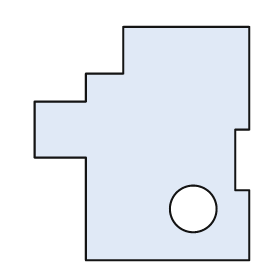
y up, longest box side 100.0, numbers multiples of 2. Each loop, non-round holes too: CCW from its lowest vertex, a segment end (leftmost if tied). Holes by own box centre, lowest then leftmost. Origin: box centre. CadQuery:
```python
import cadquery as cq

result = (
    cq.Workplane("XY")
    .moveTo(-24.0, -50.0)
    .lineTo(46.0, -50.0)
    .lineTo(46.0, -20.0)
    .lineTo(40.0, -20.0)
    .lineTo(40.0, 6.0)
    .lineTo(46.0, 6.0)
    .lineTo(46.0, 50.0)
    .lineTo(-8.0, 50.0)
    .lineTo(-8.0, 30.0)
    .lineTo(-24.0, 30.0)
    .lineTo(-24.0, 18.0)
    .lineTo(-46.0, 18.0)
    .lineTo(-46.0, -6.0)
    .lineTo(-24.0, -6.0)
    .close()
    .moveTo(22.0, -28.0)
    .circle(10.0)
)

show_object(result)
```